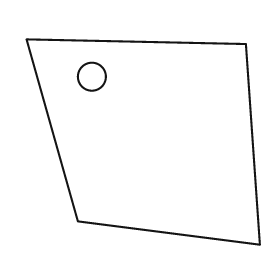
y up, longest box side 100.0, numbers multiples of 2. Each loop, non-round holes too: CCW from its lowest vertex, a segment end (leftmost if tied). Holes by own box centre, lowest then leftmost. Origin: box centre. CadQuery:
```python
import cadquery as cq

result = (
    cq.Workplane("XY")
    .moveTo(50.0, -44.0)
    .lineTo(44.0, 42.0)
    .lineTo(-50.0, 44.0)
    .lineTo(-28.0, -34.0)
    .close()
    .moveTo(-22.0, 28.0)
    .circle(6.0)
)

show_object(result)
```